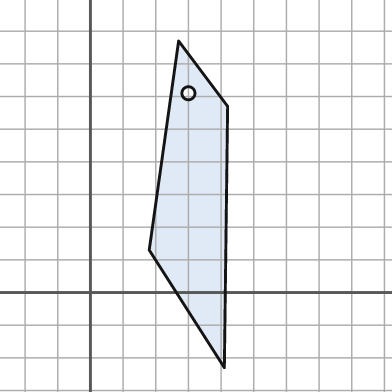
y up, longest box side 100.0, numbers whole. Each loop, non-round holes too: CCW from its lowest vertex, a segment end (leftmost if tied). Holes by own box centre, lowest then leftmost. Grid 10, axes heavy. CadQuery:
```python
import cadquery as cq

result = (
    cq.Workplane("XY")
    .moveTo(41.0, -23.0)
    .lineTo(42.0, 57.0)
    .lineTo(27.0, 77.0)
    .lineTo(18.0, 13.0)
    .close()
    .moveTo(30.0, 61.0)
    .circle(2.0)
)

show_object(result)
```